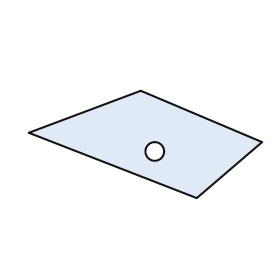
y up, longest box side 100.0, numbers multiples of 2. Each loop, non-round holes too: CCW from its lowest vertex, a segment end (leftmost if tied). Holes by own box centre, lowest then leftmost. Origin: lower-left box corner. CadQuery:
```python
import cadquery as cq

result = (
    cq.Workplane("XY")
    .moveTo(72.0, 0.0)
    .lineTo(100.0, 24.0)
    .lineTo(48.0, 46.0)
    .lineTo(0.0, 28.0)
    .close()
    .moveTo(54.0, 20.0)
    .circle(4.0)
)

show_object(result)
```